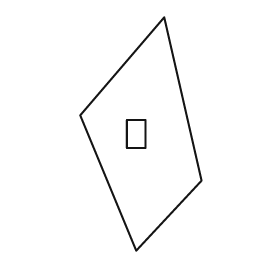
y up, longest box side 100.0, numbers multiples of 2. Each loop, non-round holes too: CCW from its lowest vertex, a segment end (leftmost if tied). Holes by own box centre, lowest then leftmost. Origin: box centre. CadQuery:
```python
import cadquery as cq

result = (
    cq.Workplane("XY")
    .moveTo(-2.0, -50.0)
    .lineTo(26.0, -20.0)
    .lineTo(10.0, 50.0)
    .lineTo(-26.0, 8.0)
    .close()
    .moveTo(-6.0, -6.0)
    .lineTo(2.0, -6.0)
    .lineTo(2.0, 6.0)
    .lineTo(-6.0, 6.0)
    .close()
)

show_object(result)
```